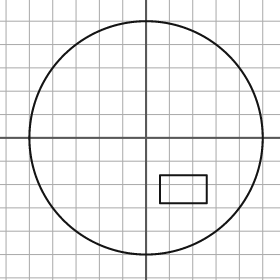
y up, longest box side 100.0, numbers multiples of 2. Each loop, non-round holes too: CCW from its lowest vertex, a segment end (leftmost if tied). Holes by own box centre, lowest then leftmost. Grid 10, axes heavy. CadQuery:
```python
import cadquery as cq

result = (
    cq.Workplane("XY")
    .moveTo(0.0, 0.0)
    .circle(50.0)
    .moveTo(6.0, -28.0)
    .lineTo(26.0, -28.0)
    .lineTo(26.0, -16.0)
    .lineTo(6.0, -16.0)
    .close()
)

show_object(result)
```